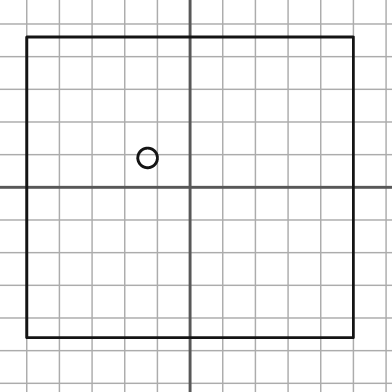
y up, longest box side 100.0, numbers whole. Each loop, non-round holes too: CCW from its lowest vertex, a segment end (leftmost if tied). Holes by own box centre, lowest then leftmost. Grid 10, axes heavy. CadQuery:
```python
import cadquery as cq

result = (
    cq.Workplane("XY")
    .moveTo(-50.0, -46.0)
    .lineTo(50.0, -46.0)
    .lineTo(50.0, 46.0)
    .lineTo(-50.0, 46.0)
    .close()
    .moveTo(-13.0, 9.0)
    .circle(3.0)
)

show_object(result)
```